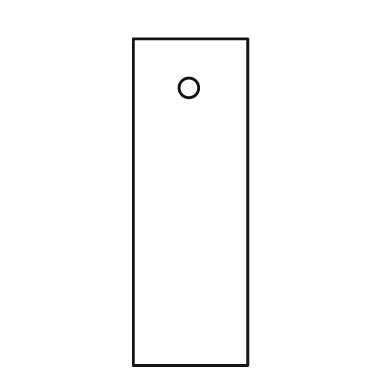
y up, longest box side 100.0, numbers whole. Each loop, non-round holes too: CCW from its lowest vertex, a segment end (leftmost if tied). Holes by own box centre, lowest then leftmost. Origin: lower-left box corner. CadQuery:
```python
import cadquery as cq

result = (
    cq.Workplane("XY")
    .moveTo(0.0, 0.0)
    .lineTo(35.0, 0.0)
    .lineTo(35.0, 100.0)
    .lineTo(0.0, 100.0)
    .close()
    .moveTo(17.0, 85.0)
    .circle(3.0)
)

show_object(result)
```